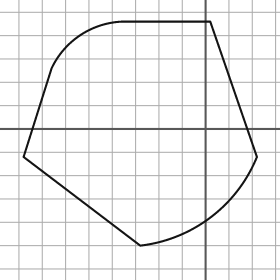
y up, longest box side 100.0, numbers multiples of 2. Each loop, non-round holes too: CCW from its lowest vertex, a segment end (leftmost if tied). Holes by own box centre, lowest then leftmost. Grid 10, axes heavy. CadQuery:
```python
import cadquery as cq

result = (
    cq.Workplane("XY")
    .moveTo(-28.0, -50.0)
    .threePointArc((2.0, -38.0), (22.0, -12.0))
    .lineTo(2.0, 46.0)
    .lineTo(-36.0, 46.0)
    .threePointArc((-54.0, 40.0), (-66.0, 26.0))
    .lineTo(-78.0, -12.0)
    .close()
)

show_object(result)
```